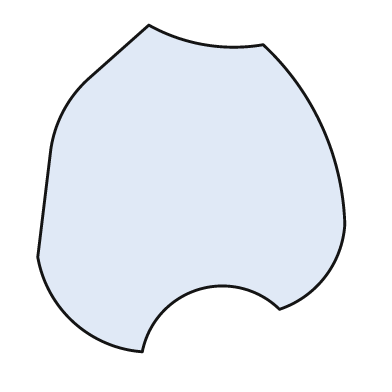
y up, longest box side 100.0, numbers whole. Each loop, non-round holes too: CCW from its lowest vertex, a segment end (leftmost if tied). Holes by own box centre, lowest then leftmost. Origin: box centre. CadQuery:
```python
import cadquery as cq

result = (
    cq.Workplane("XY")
    .moveTo(-15.0, -50.0)
    .threePointArc((2.0, -31.0), (27.0, -37.0))
    .threePointArc((41.0, -27.0), (47.0, -11.0))
    .threePointArc((40.0, 19.0), (22.0, 44.0))
    .threePointArc((4.0, 44.0), (-13.0, 50.0))
    .lineTo(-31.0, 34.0)
    .threePointArc((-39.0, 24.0), (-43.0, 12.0))
    .lineTo(-47.0, -21.0)
    .threePointArc((-36.0, -41.0), (-15.0, -50.0))
    .close()
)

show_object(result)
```